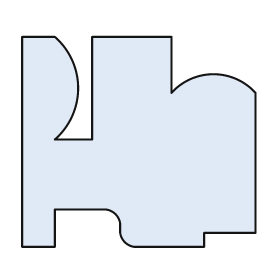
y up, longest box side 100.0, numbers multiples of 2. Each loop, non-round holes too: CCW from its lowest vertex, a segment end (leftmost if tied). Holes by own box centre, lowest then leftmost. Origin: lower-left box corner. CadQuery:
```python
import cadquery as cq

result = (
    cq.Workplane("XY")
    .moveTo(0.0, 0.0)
    .lineTo(14.0, 0.0)
    .lineTo(14.0, 16.0)
    .lineTo(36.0, 16.0)
    .threePointArc((40.0, 14.0), (42.0, 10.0))
    .lineTo(42.0, 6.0)
    .threePointArc((44.0, 2.0), (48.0, 0.0))
    .lineTo(78.0, 0.0)
    .lineTo(78.0, 6.0)
    .lineTo(100.0, 6.0)
    .lineTo(100.0, 66.0)
    .threePointArc((82.0, 74.0), (64.0, 66.0))
    .lineTo(64.0, 90.0)
    .lineTo(30.0, 90.0)
    .lineTo(30.0, 46.0)
    .lineTo(14.0, 46.0)
    .threePointArc((24.0, 68.0), (14.0, 90.0))
    .lineTo(0.0, 90.0)
    .close()
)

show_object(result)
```